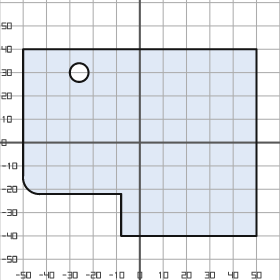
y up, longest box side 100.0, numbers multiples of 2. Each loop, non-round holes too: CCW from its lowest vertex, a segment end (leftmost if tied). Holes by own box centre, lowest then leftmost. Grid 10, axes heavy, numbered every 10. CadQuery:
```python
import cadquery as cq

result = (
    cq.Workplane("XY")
    .moveTo(-8.0, -40.0)
    .lineTo(50.0, -40.0)
    .lineTo(50.0, 40.0)
    .lineTo(-50.0, 40.0)
    .lineTo(-50.0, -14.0)
    .threePointArc((-48.0, -20.0), (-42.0, -22.0))
    .lineTo(-8.0, -22.0)
    .close()
    .moveTo(-26.0, 30.0)
    .circle(4.0)
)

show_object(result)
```